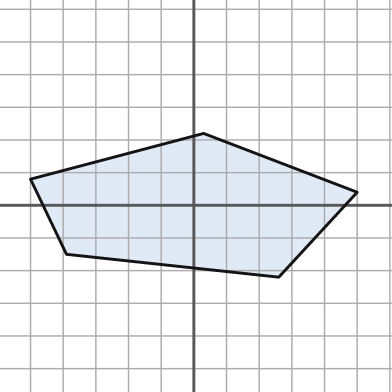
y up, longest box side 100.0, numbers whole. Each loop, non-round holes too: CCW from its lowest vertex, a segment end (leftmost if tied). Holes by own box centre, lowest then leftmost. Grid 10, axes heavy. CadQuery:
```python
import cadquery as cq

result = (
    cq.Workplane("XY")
    .moveTo(26.0, -22.0)
    .lineTo(50.0, 4.0)
    .lineTo(3.0, 22.0)
    .lineTo(-50.0, 8.0)
    .lineTo(-39.0, -15.0)
    .close()
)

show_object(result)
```